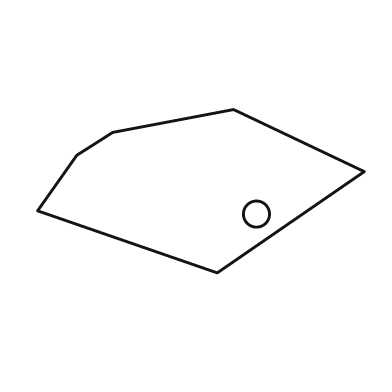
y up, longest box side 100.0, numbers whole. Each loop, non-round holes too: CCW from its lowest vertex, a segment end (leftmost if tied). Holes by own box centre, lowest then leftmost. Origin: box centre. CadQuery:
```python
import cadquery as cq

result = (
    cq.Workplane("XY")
    .moveTo(5.0, -25.0)
    .lineTo(50.0, 6.0)
    .lineTo(10.0, 25.0)
    .lineTo(-27.0, 18.0)
    .lineTo(-38.0, 11.0)
    .lineTo(-50.0, -6.0)
    .close()
    .moveTo(17.0, -7.0)
    .circle(4.0)
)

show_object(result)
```